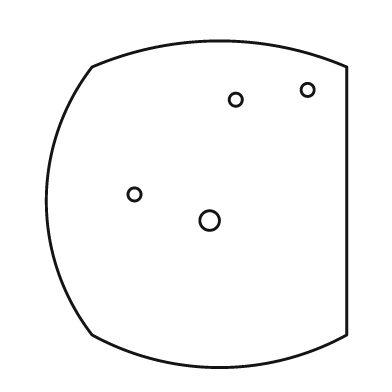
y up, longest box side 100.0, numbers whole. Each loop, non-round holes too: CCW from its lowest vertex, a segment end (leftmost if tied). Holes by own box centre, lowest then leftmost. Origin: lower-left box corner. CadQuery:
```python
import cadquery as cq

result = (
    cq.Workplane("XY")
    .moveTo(14.0, 10.0)
    .threePointArc((53.0, 0.0), (92.0, 10.0))
    .lineTo(92.0, 92.0)
    .threePointArc((53.0, 100.0), (14.0, 92.0))
    .threePointArc((0.0, 51.0), (14.0, 10.0))
    .close()
    .moveTo(50.0, 45.0)
    .circle(3.0)
    .moveTo(27.0, 53.0)
    .circle(2.0)
    .moveTo(58.0, 82.0)
    .circle(2.0)
    .moveTo(80.0, 85.0)
    .circle(2.0)
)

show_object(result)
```